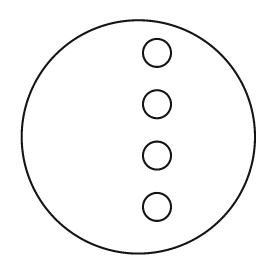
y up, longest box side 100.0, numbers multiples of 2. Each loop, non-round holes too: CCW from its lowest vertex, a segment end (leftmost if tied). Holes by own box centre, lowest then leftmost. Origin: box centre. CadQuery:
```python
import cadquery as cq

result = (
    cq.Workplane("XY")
    .moveTo(0.0, 0.0)
    .circle(50.0)
    .moveTo(8.0, -30.0)
    .circle(6.0)
    .moveTo(8.0, -8.0)
    .circle(6.0)
    .moveTo(8.0, 14.0)
    .circle(6.0)
    .moveTo(8.0, 36.0)
    .circle(6.0)
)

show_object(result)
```